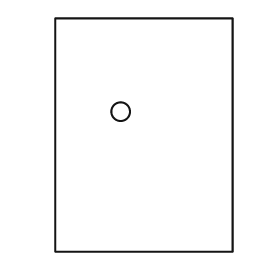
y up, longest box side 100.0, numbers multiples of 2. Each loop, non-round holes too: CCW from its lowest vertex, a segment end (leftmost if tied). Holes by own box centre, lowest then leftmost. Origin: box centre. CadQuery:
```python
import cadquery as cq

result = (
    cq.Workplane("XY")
    .moveTo(-38.0, -50.0)
    .lineTo(38.0, -50.0)
    .lineTo(38.0, 50.0)
    .lineTo(-38.0, 50.0)
    .close()
    .moveTo(-10.0, 10.0)
    .circle(4.0)
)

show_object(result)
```